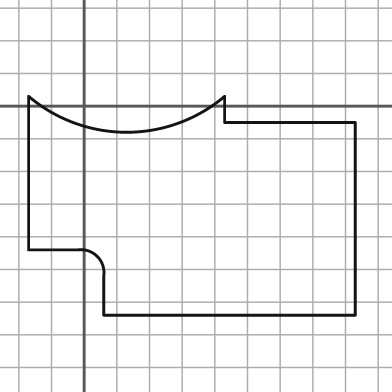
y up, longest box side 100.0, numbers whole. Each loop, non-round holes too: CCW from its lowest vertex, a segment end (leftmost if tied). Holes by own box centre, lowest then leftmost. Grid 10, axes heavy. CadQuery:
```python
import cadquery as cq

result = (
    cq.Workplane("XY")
    .moveTo(6.0, -64.0)
    .lineTo(83.0, -64.0)
    .lineTo(83.0, -5.0)
    .lineTo(43.0, -5.0)
    .lineTo(43.0, 3.0)
    .threePointArc((13.0, -8.0), (-17.0, 3.0))
    .lineTo(-17.0, -44.0)
    .lineTo(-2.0, -44.0)
    .threePointArc((4.0, -46.0), (6.0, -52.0))
    .close()
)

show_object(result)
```